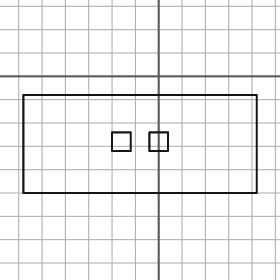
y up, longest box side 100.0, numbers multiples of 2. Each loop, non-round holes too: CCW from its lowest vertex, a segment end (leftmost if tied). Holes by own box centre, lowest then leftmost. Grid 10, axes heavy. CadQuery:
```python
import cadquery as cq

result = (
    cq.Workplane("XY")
    .moveTo(-58.0, -50.0)
    .lineTo(42.0, -50.0)
    .lineTo(42.0, -8.0)
    .lineTo(-58.0, -8.0)
    .close()
    .moveTo(-20.0, -32.0)
    .lineTo(-12.0, -32.0)
    .lineTo(-12.0, -24.0)
    .lineTo(-20.0, -24.0)
    .close()
    .moveTo(-4.0, -32.0)
    .lineTo(4.0, -32.0)
    .lineTo(4.0, -24.0)
    .lineTo(-4.0, -24.0)
    .close()
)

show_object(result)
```